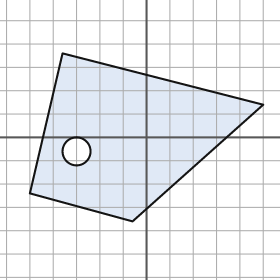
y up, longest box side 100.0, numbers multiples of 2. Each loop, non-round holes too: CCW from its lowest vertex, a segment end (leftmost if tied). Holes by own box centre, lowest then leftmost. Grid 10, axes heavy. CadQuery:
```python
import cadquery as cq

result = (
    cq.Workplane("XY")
    .moveTo(-6.0, -36.0)
    .lineTo(50.0, 14.0)
    .lineTo(-36.0, 36.0)
    .lineTo(-50.0, -24.0)
    .close()
    .moveTo(-30.0, -6.0)
    .circle(6.0)
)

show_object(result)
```